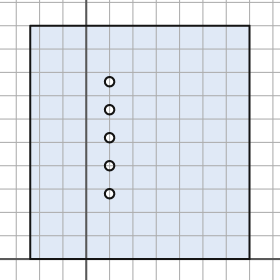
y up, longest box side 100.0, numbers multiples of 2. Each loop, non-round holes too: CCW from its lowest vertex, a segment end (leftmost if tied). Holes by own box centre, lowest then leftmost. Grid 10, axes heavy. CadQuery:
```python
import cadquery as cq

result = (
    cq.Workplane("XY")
    .moveTo(-24.0, 0.0)
    .lineTo(70.0, 0.0)
    .lineTo(70.0, 100.0)
    .lineTo(-24.0, 100.0)
    .close()
    .moveTo(10.0, 28.0)
    .circle(2.0)
    .moveTo(10.0, 40.0)
    .circle(2.0)
    .moveTo(10.0, 52.0)
    .circle(2.0)
    .moveTo(10.0, 64.0)
    .circle(2.0)
    .moveTo(10.0, 76.0)
    .circle(2.0)
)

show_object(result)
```